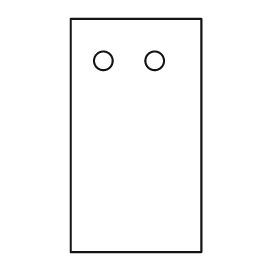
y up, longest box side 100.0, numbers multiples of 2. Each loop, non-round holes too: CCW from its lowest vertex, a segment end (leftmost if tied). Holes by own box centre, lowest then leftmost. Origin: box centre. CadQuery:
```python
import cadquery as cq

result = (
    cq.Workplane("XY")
    .moveTo(-28.0, -50.0)
    .lineTo(28.0, -50.0)
    .lineTo(28.0, 50.0)
    .lineTo(-28.0, 50.0)
    .close()
    .moveTo(-14.0, 32.0)
    .circle(4.0)
    .moveTo(8.0, 32.0)
    .circle(4.0)
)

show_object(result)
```